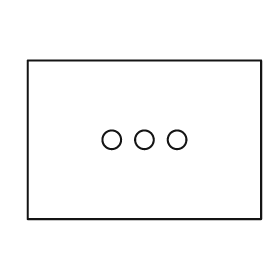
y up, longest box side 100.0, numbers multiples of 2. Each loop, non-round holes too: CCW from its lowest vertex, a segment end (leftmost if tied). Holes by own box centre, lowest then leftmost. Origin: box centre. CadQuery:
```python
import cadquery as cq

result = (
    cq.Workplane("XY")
    .moveTo(-50.0, -34.0)
    .lineTo(50.0, -34.0)
    .lineTo(50.0, 34.0)
    .lineTo(-50.0, 34.0)
    .close()
    .moveTo(-14.0, 0.0)
    .circle(4.0)
    .moveTo(0.0, 0.0)
    .circle(4.0)
    .moveTo(14.0, 0.0)
    .circle(4.0)
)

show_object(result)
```